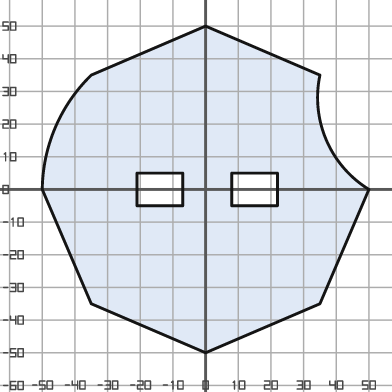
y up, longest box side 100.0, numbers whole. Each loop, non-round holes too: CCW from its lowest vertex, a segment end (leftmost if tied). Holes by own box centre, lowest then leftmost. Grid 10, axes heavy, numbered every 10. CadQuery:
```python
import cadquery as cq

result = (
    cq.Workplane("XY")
    .moveTo(0.0, -50.0)
    .lineTo(35.0, -35.0)
    .lineTo(50.0, 0.0)
    .threePointArc((37.0, 15.0), (35.0, 35.0))
    .lineTo(0.0, 50.0)
    .lineTo(-35.0, 35.0)
    .threePointArc((-46.0, 19.0), (-50.0, 0.0))
    .lineTo(-35.0, -35.0)
    .close()
    .moveTo(-21.0, -5.0)
    .lineTo(-7.0, -5.0)
    .lineTo(-7.0, 5.0)
    .lineTo(-21.0, 5.0)
    .close()
    .moveTo(8.0, -5.0)
    .lineTo(22.0, -5.0)
    .lineTo(22.0, 5.0)
    .lineTo(8.0, 5.0)
    .close()
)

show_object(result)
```